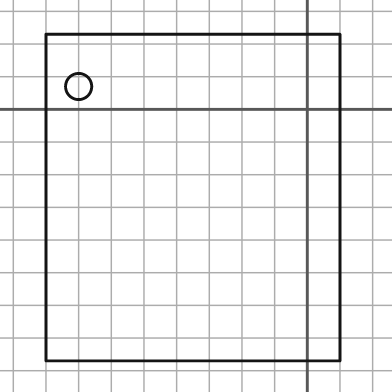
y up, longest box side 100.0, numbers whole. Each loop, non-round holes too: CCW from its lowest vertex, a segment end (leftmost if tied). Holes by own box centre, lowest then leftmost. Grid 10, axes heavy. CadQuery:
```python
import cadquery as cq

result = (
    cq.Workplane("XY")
    .moveTo(-80.0, -77.0)
    .lineTo(10.0, -77.0)
    .lineTo(10.0, 23.0)
    .lineTo(-80.0, 23.0)
    .close()
    .moveTo(-70.0, 7.0)
    .circle(4.0)
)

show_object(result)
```